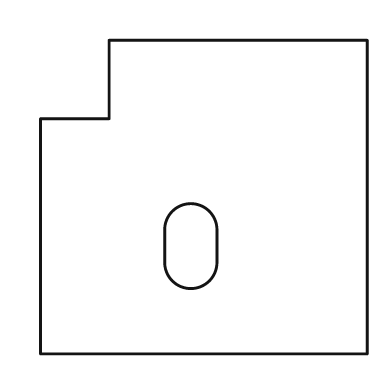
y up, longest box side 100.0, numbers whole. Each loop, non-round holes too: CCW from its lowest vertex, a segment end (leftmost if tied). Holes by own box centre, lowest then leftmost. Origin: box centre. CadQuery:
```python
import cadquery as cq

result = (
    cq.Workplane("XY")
    .moveTo(-50.0, -48.0)
    .lineTo(50.0, -48.0)
    .lineTo(50.0, 48.0)
    .lineTo(-29.0, 48.0)
    .lineTo(-29.0, 24.0)
    .lineTo(-50.0, 24.0)
    .close()
    .moveTo(-12.0, -20.0)
    .threePointArc((-4.0, -28.0), (4.0, -20.0))
    .lineTo(4.0, -10.0)
    .threePointArc((-4.0, -2.0), (-12.0, -10.0))
    .close()
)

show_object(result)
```